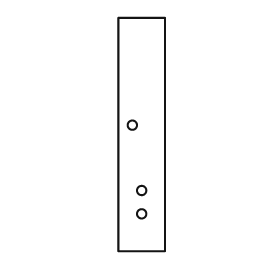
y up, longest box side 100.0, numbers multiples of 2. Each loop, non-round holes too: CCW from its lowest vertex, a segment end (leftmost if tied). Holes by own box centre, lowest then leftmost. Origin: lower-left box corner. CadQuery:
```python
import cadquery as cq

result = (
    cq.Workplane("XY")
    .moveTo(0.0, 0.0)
    .lineTo(20.0, 0.0)
    .lineTo(20.0, 100.0)
    .lineTo(0.0, 100.0)
    .close()
    .moveTo(10.0, 16.0)
    .circle(2.0)
    .moveTo(10.0, 26.0)
    .circle(2.0)
    .moveTo(6.0, 54.0)
    .circle(2.0)
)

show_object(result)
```